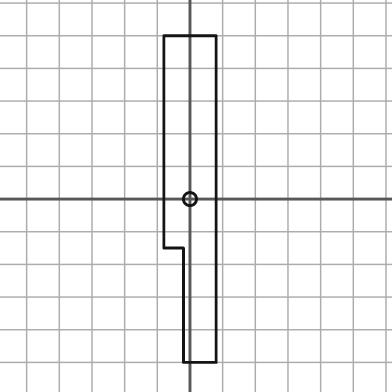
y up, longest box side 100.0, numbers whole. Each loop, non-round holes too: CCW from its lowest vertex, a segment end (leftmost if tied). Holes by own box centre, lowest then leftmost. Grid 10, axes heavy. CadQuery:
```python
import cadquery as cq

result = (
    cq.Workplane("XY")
    .moveTo(-2.0, -50.0)
    .lineTo(8.0, -50.0)
    .lineTo(8.0, 50.0)
    .lineTo(-8.0, 50.0)
    .lineTo(-8.0, -15.0)
    .lineTo(-2.0, -15.0)
    .close()
    .moveTo(0.0, 0.0)
    .circle(2.0)
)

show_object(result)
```